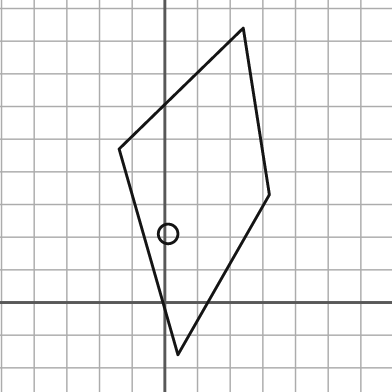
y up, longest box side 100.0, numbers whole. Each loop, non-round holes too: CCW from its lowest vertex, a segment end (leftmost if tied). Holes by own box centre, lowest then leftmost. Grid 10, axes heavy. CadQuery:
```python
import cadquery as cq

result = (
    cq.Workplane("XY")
    .moveTo(4.0, -16.0)
    .lineTo(32.0, 33.0)
    .lineTo(24.0, 84.0)
    .lineTo(-14.0, 47.0)
    .close()
    .moveTo(1.0, 21.0)
    .circle(3.0)
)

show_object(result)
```